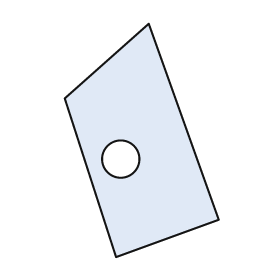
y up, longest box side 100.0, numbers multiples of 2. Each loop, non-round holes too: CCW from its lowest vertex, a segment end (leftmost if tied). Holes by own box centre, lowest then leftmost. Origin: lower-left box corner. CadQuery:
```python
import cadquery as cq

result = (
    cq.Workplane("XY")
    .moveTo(22.0, 0.0)
    .lineTo(66.0, 16.0)
    .lineTo(36.0, 100.0)
    .lineTo(0.0, 68.0)
    .close()
    .moveTo(24.0, 42.0)
    .circle(8.0)
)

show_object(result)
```